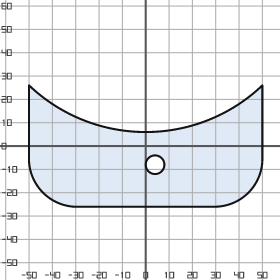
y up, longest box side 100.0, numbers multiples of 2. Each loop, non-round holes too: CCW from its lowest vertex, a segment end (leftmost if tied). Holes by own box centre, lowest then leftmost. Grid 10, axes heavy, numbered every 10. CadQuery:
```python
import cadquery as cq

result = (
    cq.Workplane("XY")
    .moveTo(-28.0, -26.0)
    .lineTo(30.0, -26.0)
    .threePointArc((44.0, -20.0), (50.0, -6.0))
    .lineTo(50.0, 26.0)
    .threePointArc((0.0, 6.0), (-50.0, 26.0))
    .lineTo(-50.0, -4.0)
    .threePointArc((-44.0, -20.0), (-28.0, -26.0))
    .close()
    .moveTo(4.0, -8.0)
    .circle(4.0)
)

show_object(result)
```